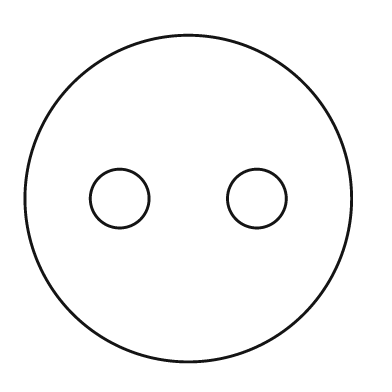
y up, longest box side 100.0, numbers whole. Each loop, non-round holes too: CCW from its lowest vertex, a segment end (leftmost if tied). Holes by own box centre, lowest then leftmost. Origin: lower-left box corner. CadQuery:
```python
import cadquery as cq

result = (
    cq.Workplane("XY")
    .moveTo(50.0, 50.0)
    .circle(50.0)
    .moveTo(29.0, 50.0)
    .circle(9.0)
    .moveTo(71.0, 50.0)
    .circle(9.0)
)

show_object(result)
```